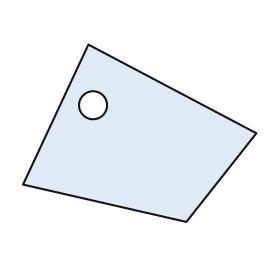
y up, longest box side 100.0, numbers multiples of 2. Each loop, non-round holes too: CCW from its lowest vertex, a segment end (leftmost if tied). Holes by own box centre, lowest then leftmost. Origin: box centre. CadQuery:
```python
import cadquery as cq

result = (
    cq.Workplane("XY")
    .moveTo(20.0, -38.0)
    .lineTo(50.0, 0.0)
    .lineTo(-22.0, 38.0)
    .lineTo(-50.0, -22.0)
    .close()
    .moveTo(-20.0, 12.0)
    .circle(6.0)
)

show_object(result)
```